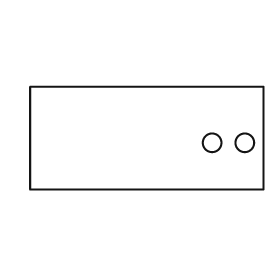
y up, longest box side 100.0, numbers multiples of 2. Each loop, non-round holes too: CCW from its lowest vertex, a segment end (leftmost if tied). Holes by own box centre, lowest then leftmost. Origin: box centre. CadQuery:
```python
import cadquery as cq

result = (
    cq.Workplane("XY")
    .moveTo(-50.0, -22.0)
    .lineTo(50.0, -22.0)
    .lineTo(50.0, 22.0)
    .lineTo(-50.0, 22.0)
    .close()
    .moveTo(28.0, -2.0)
    .circle(4.0)
    .moveTo(42.0, -2.0)
    .circle(4.0)
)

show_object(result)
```